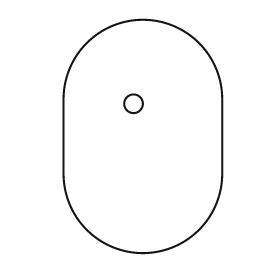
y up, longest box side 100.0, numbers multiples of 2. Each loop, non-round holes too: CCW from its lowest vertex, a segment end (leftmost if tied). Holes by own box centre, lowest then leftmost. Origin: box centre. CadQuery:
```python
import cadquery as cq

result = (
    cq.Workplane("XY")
    .moveTo(-34.0, -16.0)
    .threePointArc((0.0, -50.0), (34.0, -16.0))
    .lineTo(34.0, 16.0)
    .threePointArc((0.0, 50.0), (-34.0, 16.0))
    .close()
    .moveTo(-4.0, 14.0)
    .circle(4.0)
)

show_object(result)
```